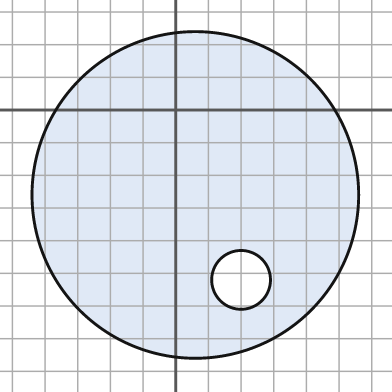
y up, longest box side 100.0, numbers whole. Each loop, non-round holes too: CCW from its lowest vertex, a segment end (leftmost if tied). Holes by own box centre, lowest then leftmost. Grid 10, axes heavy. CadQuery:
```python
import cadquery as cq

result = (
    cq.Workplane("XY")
    .moveTo(6.0, -26.0)
    .circle(50.0)
    .moveTo(20.0, -52.0)
    .circle(9.0)
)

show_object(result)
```